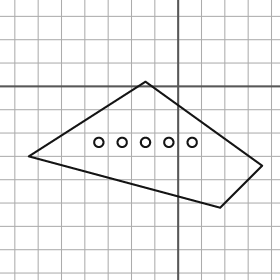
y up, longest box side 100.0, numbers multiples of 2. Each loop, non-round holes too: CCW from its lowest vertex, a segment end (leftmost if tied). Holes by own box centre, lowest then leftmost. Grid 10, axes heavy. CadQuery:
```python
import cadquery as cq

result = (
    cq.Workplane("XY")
    .moveTo(18.0, -52.0)
    .lineTo(36.0, -34.0)
    .lineTo(-14.0, 2.0)
    .lineTo(-64.0, -30.0)
    .close()
    .moveTo(-34.0, -24.0)
    .circle(2.0)
    .moveTo(-24.0, -24.0)
    .circle(2.0)
    .moveTo(-14.0, -24.0)
    .circle(2.0)
    .moveTo(-4.0, -24.0)
    .circle(2.0)
    .moveTo(6.0, -24.0)
    .circle(2.0)
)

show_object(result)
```